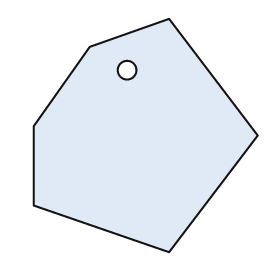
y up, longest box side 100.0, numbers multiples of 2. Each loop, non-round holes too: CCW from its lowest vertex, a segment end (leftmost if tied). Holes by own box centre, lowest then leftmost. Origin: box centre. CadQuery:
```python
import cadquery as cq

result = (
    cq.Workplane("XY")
    .moveTo(10.0, -50.0)
    .lineTo(48.0, 0.0)
    .lineTo(10.0, 50.0)
    .lineTo(-24.0, 38.0)
    .lineTo(-48.0, 4.0)
    .lineTo(-48.0, -30.0)
    .close()
    .moveTo(-8.0, 28.0)
    .circle(4.0)
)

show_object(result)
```